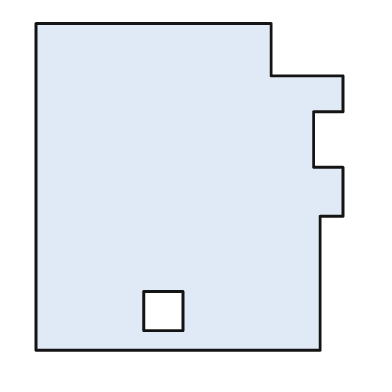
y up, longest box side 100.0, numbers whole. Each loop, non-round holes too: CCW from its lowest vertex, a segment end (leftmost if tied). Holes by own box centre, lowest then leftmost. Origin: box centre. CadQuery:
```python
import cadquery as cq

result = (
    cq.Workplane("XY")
    .moveTo(-47.0, -50.0)
    .lineTo(40.0, -50.0)
    .lineTo(40.0, -9.0)
    .lineTo(47.0, -9.0)
    .lineTo(47.0, 6.0)
    .lineTo(38.0, 6.0)
    .lineTo(38.0, 23.0)
    .lineTo(47.0, 23.0)
    .lineTo(47.0, 34.0)
    .lineTo(25.0, 34.0)
    .lineTo(25.0, 50.0)
    .lineTo(-47.0, 50.0)
    .close()
    .moveTo(-14.0, -44.0)
    .lineTo(-2.0, -44.0)
    .lineTo(-2.0, -32.0)
    .lineTo(-14.0, -32.0)
    .close()
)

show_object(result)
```